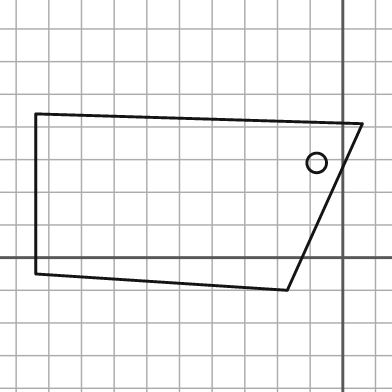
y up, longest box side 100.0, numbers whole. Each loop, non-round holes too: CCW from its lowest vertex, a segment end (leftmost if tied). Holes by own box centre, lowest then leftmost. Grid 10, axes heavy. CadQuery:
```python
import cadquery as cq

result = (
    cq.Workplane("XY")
    .moveTo(-17.0, -10.0)
    .lineTo(6.0, 41.0)
    .lineTo(-94.0, 44.0)
    .lineTo(-94.0, -5.0)
    .close()
    .moveTo(-8.0, 29.0)
    .circle(3.0)
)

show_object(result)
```